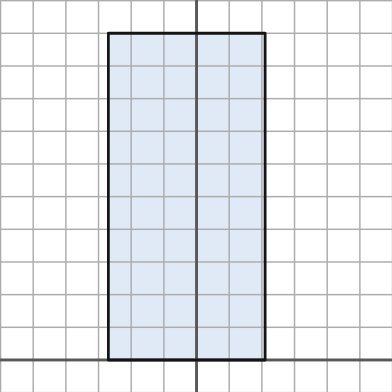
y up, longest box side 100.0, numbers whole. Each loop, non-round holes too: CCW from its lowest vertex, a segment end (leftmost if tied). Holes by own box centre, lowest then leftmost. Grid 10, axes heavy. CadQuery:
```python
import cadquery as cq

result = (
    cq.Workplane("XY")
    .moveTo(-27.0, 0.0)
    .lineTo(21.0, 0.0)
    .lineTo(21.0, 100.0)
    .lineTo(-27.0, 100.0)
    .close()
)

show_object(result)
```